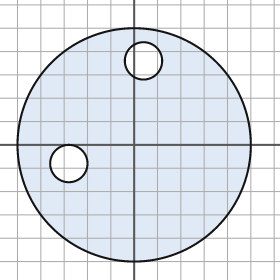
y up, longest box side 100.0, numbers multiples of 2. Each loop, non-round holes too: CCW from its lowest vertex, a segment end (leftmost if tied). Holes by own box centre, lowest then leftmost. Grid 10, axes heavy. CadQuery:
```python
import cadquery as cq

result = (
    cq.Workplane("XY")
    .moveTo(0.0, 0.0)
    .circle(50.0)
    .moveTo(-28.0, -8.0)
    .circle(8.0)
    .moveTo(4.0, 36.0)
    .circle(8.0)
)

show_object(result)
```